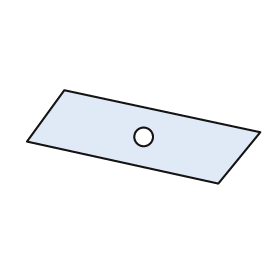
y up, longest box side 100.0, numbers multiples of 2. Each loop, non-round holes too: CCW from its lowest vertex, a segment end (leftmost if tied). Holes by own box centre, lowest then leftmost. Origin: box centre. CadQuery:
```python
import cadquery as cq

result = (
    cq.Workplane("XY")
    .moveTo(32.0, -20.0)
    .lineTo(50.0, 2.0)
    .lineTo(-34.0, 20.0)
    .lineTo(-50.0, -2.0)
    .close()
    .moveTo(0.0, 0.0)
    .circle(4.0)
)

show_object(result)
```